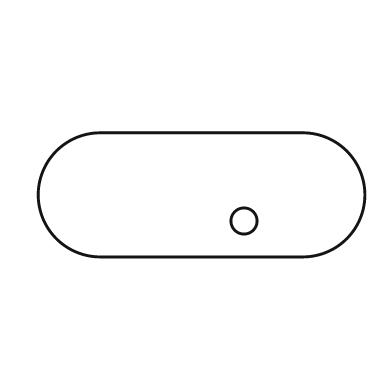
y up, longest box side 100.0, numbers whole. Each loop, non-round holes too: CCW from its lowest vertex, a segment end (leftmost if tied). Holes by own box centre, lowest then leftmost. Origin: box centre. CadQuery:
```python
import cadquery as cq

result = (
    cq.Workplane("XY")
    .moveTo(-31.0, -19.0)
    .lineTo(31.0, -19.0)
    .threePointArc((50.0, 0.0), (31.0, 19.0))
    .lineTo(-31.0, 19.0)
    .threePointArc((-50.0, 0.0), (-31.0, -19.0))
    .close()
    .moveTo(13.0, -8.0)
    .circle(4.0)
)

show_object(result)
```